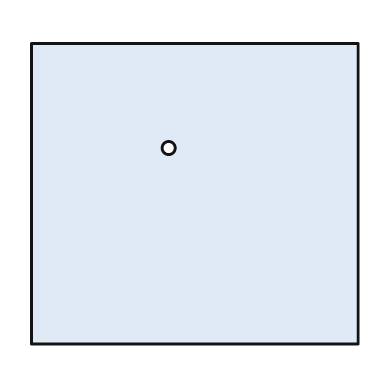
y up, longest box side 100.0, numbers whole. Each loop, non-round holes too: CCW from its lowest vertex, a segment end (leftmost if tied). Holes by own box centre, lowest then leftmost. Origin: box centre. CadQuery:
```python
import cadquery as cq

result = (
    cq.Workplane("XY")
    .moveTo(-50.0, -46.0)
    .lineTo(50.0, -46.0)
    .lineTo(50.0, 46.0)
    .lineTo(-50.0, 46.0)
    .close()
    .moveTo(-8.0, 14.0)
    .circle(2.0)
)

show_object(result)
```